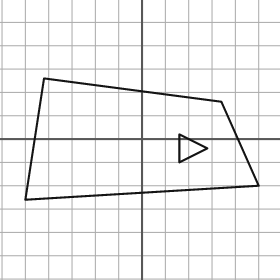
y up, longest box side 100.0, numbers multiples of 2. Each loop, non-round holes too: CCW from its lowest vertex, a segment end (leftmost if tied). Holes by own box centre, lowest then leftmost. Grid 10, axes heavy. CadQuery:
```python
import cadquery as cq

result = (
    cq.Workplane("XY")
    .moveTo(-50.0, -26.0)
    .lineTo(50.0, -20.0)
    .lineTo(34.0, 16.0)
    .lineTo(-42.0, 26.0)
    .close()
    .moveTo(16.0, -10.0)
    .lineTo(28.0, -4.0)
    .lineTo(16.0, 2.0)
    .close()
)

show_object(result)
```